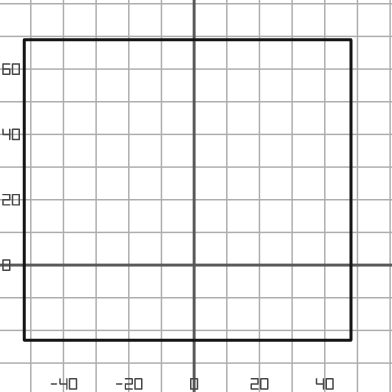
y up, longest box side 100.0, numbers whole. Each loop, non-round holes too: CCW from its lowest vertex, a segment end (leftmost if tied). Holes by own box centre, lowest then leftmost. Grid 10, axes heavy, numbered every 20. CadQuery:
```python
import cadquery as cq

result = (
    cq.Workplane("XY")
    .moveTo(-52.0, -23.0)
    .lineTo(48.0, -23.0)
    .lineTo(48.0, 69.0)
    .lineTo(-52.0, 69.0)
    .close()
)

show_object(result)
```